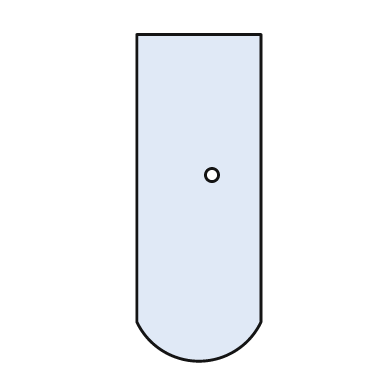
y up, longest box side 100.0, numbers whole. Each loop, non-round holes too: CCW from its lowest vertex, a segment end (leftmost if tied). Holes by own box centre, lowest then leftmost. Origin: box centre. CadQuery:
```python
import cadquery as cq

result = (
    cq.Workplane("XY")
    .moveTo(-19.0, -38.0)
    .threePointArc((0.0, -50.0), (19.0, -38.0))
    .lineTo(19.0, 50.0)
    .lineTo(-19.0, 50.0)
    .close()
    .moveTo(4.0, 7.0)
    .circle(2.0)
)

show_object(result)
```